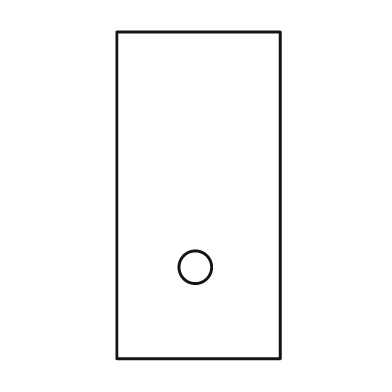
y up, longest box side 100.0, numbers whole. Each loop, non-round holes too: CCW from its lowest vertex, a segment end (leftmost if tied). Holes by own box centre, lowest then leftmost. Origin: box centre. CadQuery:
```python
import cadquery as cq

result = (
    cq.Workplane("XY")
    .moveTo(-25.0, -50.0)
    .lineTo(25.0, -50.0)
    .lineTo(25.0, 50.0)
    .lineTo(-25.0, 50.0)
    .close()
    .moveTo(-1.0, -22.0)
    .circle(5.0)
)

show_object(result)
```